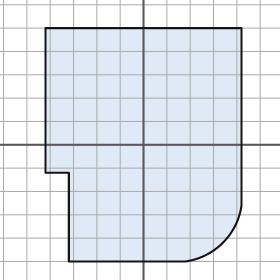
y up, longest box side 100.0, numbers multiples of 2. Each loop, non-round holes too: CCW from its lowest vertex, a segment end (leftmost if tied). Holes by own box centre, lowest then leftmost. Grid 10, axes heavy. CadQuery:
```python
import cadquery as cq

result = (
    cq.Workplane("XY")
    .moveTo(-32.0, -50.0)
    .lineTo(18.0, -50.0)
    .threePointArc((34.0, -42.0), (42.0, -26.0))
    .lineTo(42.0, 50.0)
    .lineTo(-42.0, 50.0)
    .lineTo(-42.0, -12.0)
    .lineTo(-32.0, -12.0)
    .close()
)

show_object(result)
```